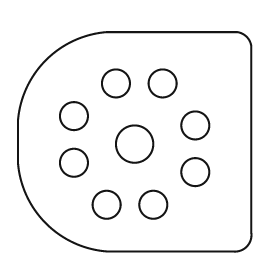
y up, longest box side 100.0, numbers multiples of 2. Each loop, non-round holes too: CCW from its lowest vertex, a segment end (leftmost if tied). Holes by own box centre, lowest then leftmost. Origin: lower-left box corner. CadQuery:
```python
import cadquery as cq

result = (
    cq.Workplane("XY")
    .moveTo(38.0, 0.0)
    .lineTo(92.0, 0.0)
    .threePointArc((98.0, 2.0), (100.0, 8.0))
    .lineTo(100.0, 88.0)
    .threePointArc((98.0, 92.0), (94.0, 94.0))
    .lineTo(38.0, 94.0)
    .threePointArc((12.0, 82.0), (0.0, 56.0))
    .lineTo(0.0, 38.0)
    .threePointArc((12.0, 12.0), (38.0, 0.0))
    .close()
    .moveTo(38.0, 20.0)
    .circle(6.0)
    .moveTo(58.0, 20.0)
    .circle(6.0)
    .moveTo(76.0, 34.0)
    .circle(6.0)
    .moveTo(24.0, 38.0)
    .circle(6.0)
    .moveTo(50.0, 46.0)
    .circle(8.0)
    .moveTo(76.0, 54.0)
    .circle(6.0)
    .moveTo(24.0, 58.0)
    .circle(6.0)
    .moveTo(42.0, 72.0)
    .circle(6.0)
    .moveTo(62.0, 72.0)
    .circle(6.0)
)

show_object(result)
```